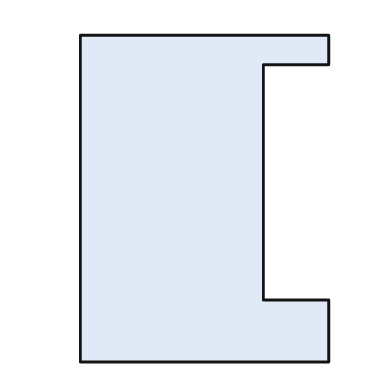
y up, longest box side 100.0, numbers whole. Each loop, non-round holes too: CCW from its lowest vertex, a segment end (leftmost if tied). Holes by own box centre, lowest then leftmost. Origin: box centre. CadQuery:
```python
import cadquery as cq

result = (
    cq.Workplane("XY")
    .moveTo(-38.0, -50.0)
    .lineTo(38.0, -50.0)
    .lineTo(38.0, -31.0)
    .lineTo(18.0, -31.0)
    .lineTo(18.0, 41.0)
    .lineTo(38.0, 41.0)
    .lineTo(38.0, 50.0)
    .lineTo(-38.0, 50.0)
    .close()
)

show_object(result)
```